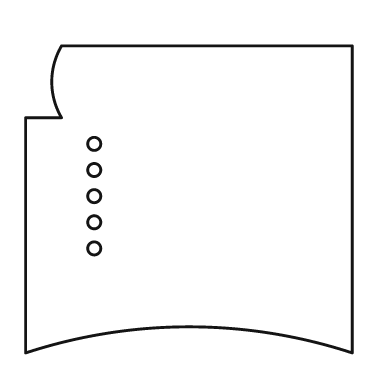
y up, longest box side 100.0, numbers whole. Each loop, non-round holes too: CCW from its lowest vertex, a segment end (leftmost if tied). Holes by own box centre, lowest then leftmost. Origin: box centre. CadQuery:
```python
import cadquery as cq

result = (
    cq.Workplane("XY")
    .moveTo(-50.0, -47.0)
    .threePointArc((0.0, -39.0), (50.0, -47.0))
    .lineTo(50.0, 47.0)
    .lineTo(-39.0, 47.0)
    .threePointArc((-42.0, 36.0), (-39.0, 25.0))
    .lineTo(-50.0, 25.0)
    .close()
    .moveTo(-29.0, -15.0)
    .circle(2.0)
    .moveTo(-29.0, -7.0)
    .circle(2.0)
    .moveTo(-29.0, 1.0)
    .circle(2.0)
    .moveTo(-29.0, 9.0)
    .circle(2.0)
    .moveTo(-29.0, 17.0)
    .circle(2.0)
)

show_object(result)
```